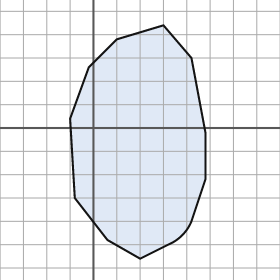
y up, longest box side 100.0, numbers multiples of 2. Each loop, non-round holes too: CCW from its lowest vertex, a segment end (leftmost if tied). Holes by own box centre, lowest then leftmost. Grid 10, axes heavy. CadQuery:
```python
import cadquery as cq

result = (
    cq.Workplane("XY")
    .moveTo(20.0, -56.0)
    .lineTo(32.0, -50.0)
    .threePointArc((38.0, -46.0), (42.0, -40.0))
    .lineTo(48.0, -22.0)
    .lineTo(48.0, -2.0)
    .lineTo(42.0, 30.0)
    .lineTo(30.0, 44.0)
    .lineTo(10.0, 38.0)
    .lineTo(-2.0, 26.0)
    .lineTo(-10.0, 4.0)
    .lineTo(-8.0, -30.0)
    .lineTo(6.0, -48.0)
    .close()
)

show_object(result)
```